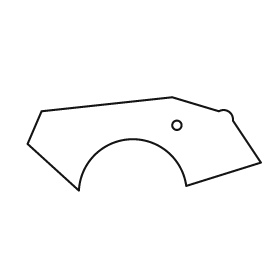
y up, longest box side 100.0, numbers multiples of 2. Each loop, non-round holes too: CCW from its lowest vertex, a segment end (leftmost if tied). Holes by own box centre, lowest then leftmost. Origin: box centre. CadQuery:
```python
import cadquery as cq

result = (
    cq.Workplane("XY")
    .moveTo(-28.0, -20.0)
    .threePointArc((-6.0, 2.0), (18.0, -18.0))
    .lineTo(50.0, -8.0)
    .lineTo(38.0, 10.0)
    .threePointArc((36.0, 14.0), (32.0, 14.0))
    .lineTo(12.0, 20.0)
    .lineTo(-44.0, 14.0)
    .lineTo(-50.0, 0.0)
    .close()
    .moveTo(14.0, 8.0)
    .circle(2.0)
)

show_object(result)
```